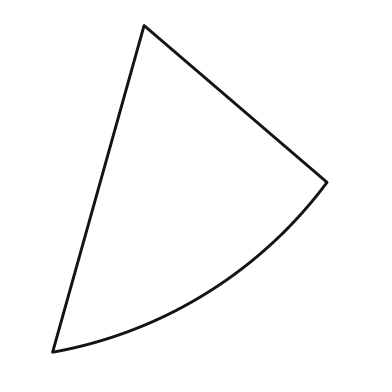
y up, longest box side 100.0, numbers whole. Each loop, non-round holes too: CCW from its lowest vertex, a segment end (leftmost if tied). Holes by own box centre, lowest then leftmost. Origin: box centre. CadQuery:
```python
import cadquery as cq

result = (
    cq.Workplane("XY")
    .moveTo(-42.0, -50.0)
    .threePointArc((5.0, -32.0), (42.0, 2.0))
    .lineTo(-14.0, 50.0)
    .close()
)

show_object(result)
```